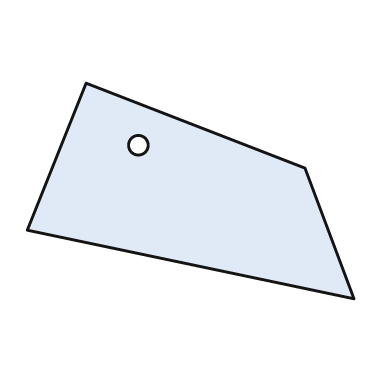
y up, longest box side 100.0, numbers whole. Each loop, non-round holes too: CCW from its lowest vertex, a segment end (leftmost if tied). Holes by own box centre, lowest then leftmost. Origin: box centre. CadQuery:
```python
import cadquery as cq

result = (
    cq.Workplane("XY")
    .moveTo(50.0, -33.0)
    .lineTo(35.0, 7.0)
    .lineTo(-32.0, 33.0)
    .lineTo(-50.0, -12.0)
    .close()
    .moveTo(-16.0, 14.0)
    .circle(3.0)
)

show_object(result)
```